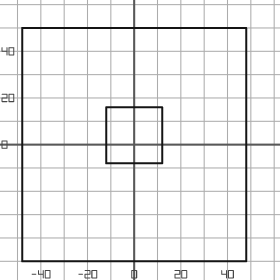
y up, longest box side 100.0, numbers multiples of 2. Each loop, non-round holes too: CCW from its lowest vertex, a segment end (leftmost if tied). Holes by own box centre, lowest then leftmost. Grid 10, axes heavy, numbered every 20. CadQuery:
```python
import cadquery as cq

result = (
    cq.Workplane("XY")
    .moveTo(-48.0, -50.0)
    .lineTo(48.0, -50.0)
    .lineTo(48.0, 50.0)
    .lineTo(-48.0, 50.0)
    .close()
    .moveTo(-12.0, -8.0)
    .lineTo(12.0, -8.0)
    .lineTo(12.0, 16.0)
    .lineTo(-12.0, 16.0)
    .close()
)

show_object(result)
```